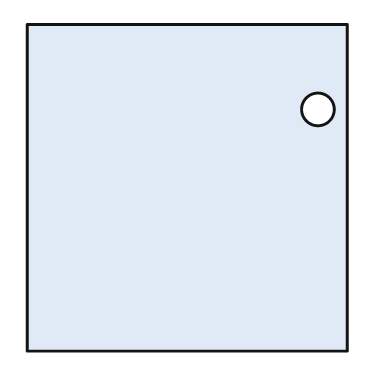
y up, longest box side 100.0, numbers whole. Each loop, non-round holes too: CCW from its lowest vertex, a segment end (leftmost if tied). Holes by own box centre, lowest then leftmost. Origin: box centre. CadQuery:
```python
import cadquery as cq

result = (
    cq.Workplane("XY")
    .moveTo(-49.0, -50.0)
    .lineTo(49.0, -50.0)
    .lineTo(49.0, 50.0)
    .lineTo(-49.0, 50.0)
    .close()
    .moveTo(40.0, 24.0)
    .circle(5.0)
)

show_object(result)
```